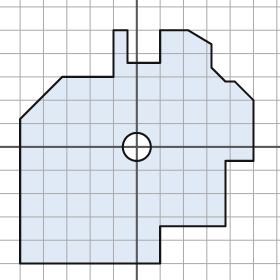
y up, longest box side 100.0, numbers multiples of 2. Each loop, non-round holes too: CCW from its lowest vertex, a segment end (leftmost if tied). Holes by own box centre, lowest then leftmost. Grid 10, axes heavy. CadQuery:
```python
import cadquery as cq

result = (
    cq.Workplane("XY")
    .moveTo(-50.0, -50.0)
    .lineTo(10.0, -50.0)
    .lineTo(10.0, -34.0)
    .lineTo(38.0, -34.0)
    .lineTo(38.0, -6.0)
    .lineTo(50.0, -6.0)
    .lineTo(50.0, 20.0)
    .lineTo(42.0, 28.0)
    .lineTo(38.0, 28.0)
    .lineTo(32.0, 34.0)
    .lineTo(32.0, 44.0)
    .lineTo(22.0, 50.0)
    .lineTo(10.0, 50.0)
    .lineTo(10.0, 36.0)
    .lineTo(-4.0, 36.0)
    .lineTo(-4.0, 50.0)
    .lineTo(-10.0, 50.0)
    .lineTo(-10.0, 30.0)
    .lineTo(-32.0, 30.0)
    .lineTo(-50.0, 12.0)
    .close()
    .moveTo(0.0, 0.0)
    .circle(6.0)
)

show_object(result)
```